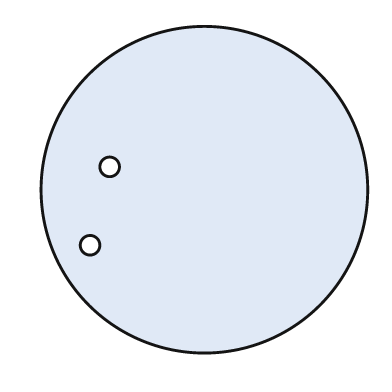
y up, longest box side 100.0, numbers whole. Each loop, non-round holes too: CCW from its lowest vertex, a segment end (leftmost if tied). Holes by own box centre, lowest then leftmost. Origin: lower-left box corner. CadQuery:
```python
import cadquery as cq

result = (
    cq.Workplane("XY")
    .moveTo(50.0, 50.0)
    .circle(50.0)
    .moveTo(15.0, 33.0)
    .circle(3.0)
    .moveTo(21.0, 57.0)
    .circle(3.0)
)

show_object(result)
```